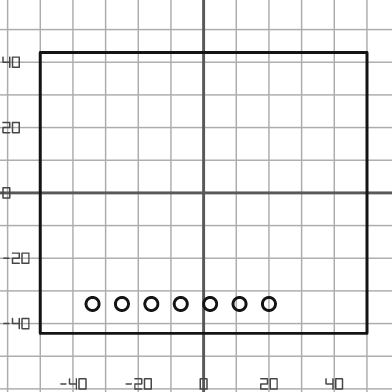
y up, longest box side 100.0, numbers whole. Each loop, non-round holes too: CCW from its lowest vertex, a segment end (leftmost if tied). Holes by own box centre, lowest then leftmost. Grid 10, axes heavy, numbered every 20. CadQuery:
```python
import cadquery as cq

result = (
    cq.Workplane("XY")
    .moveTo(-50.0, -43.0)
    .lineTo(50.0, -43.0)
    .lineTo(50.0, 43.0)
    .lineTo(-50.0, 43.0)
    .close()
    .moveTo(-34.0, -34.0)
    .circle(2.0)
    .moveTo(-25.0, -34.0)
    .circle(2.0)
    .moveTo(-16.0, -34.0)
    .circle(2.0)
    .moveTo(-7.0, -34.0)
    .circle(2.0)
    .moveTo(2.0, -34.0)
    .circle(2.0)
    .moveTo(11.0, -34.0)
    .circle(2.0)
    .moveTo(20.0, -34.0)
    .circle(2.0)
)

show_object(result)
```